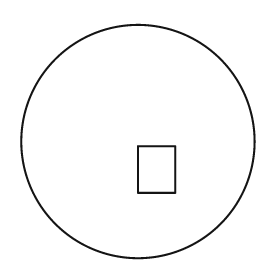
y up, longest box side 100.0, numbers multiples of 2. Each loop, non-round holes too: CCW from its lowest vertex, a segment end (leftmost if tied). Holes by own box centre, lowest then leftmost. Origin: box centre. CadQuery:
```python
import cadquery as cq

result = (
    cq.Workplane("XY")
    .moveTo(0.0, 0.0)
    .circle(50.0)
    .moveTo(0.0, -22.0)
    .lineTo(16.0, -22.0)
    .lineTo(16.0, -2.0)
    .lineTo(0.0, -2.0)
    .close()
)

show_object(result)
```